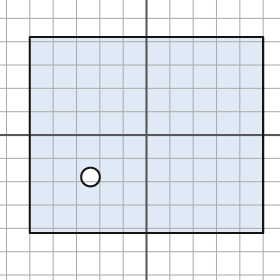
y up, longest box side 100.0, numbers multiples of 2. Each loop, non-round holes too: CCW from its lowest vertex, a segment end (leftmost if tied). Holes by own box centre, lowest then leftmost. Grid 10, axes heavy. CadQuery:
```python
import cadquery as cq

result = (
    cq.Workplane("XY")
    .moveTo(-50.0, -42.0)
    .lineTo(50.0, -42.0)
    .lineTo(50.0, 42.0)
    .lineTo(-50.0, 42.0)
    .close()
    .moveTo(-24.0, -18.0)
    .circle(4.0)
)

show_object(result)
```